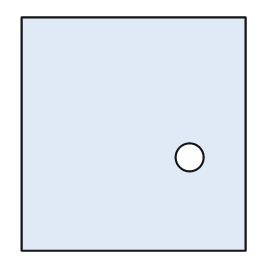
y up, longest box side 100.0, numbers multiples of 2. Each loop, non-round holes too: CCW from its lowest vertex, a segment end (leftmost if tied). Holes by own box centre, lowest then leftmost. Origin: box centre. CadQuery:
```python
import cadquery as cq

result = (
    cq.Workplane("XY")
    .moveTo(-48.0, -50.0)
    .lineTo(48.0, -50.0)
    .lineTo(48.0, 50.0)
    .lineTo(-48.0, 50.0)
    .close()
    .moveTo(24.0, -10.0)
    .circle(6.0)
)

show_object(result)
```